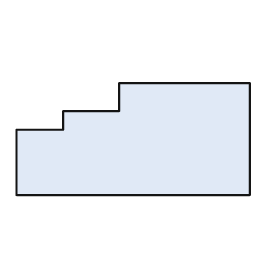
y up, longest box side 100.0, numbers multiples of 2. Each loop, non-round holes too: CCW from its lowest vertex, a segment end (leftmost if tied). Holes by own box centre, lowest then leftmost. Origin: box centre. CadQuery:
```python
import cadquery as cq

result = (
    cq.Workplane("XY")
    .moveTo(-50.0, -24.0)
    .lineTo(50.0, -24.0)
    .lineTo(50.0, 24.0)
    .lineTo(-6.0, 24.0)
    .lineTo(-6.0, 12.0)
    .lineTo(-30.0, 12.0)
    .lineTo(-30.0, 4.0)
    .lineTo(-50.0, 4.0)
    .close()
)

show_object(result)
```